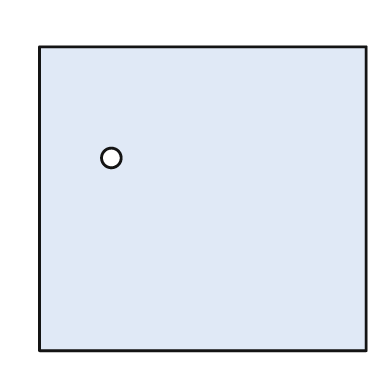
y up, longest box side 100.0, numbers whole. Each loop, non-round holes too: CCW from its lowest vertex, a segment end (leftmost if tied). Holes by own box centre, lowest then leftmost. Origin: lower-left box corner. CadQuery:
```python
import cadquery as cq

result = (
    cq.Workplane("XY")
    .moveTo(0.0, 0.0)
    .lineTo(100.0, 0.0)
    .lineTo(100.0, 93.0)
    .lineTo(0.0, 93.0)
    .close()
    .moveTo(22.0, 59.0)
    .circle(3.0)
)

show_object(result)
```